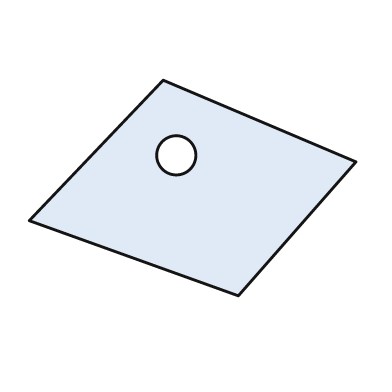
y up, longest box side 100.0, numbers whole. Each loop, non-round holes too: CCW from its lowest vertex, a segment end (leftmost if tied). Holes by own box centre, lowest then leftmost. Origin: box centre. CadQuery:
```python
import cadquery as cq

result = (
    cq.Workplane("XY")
    .moveTo(14.0, -33.0)
    .lineTo(50.0, 8.0)
    .lineTo(-9.0, 33.0)
    .lineTo(-50.0, -10.0)
    .close()
    .moveTo(-5.0, 10.0)
    .circle(6.0)
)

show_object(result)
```